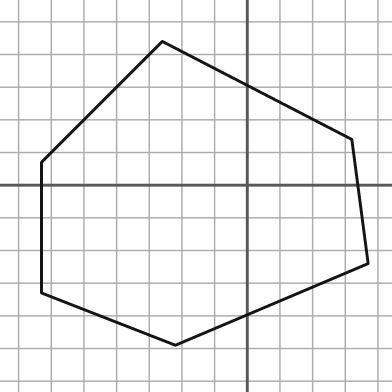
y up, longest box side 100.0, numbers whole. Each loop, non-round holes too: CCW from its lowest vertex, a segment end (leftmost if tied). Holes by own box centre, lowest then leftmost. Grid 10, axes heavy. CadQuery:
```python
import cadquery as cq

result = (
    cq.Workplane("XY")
    .moveTo(-22.0, -49.0)
    .lineTo(37.0, -24.0)
    .lineTo(32.0, 14.0)
    .lineTo(-26.0, 44.0)
    .lineTo(-63.0, 7.0)
    .lineTo(-63.0, -33.0)
    .close()
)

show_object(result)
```